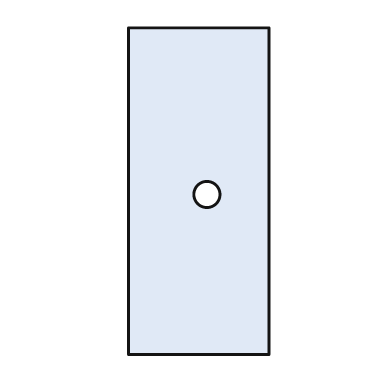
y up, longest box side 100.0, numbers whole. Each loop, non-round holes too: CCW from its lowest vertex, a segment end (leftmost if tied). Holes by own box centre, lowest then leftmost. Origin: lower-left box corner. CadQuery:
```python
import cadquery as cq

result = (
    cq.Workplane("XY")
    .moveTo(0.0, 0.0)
    .lineTo(43.0, 0.0)
    .lineTo(43.0, 100.0)
    .lineTo(0.0, 100.0)
    .close()
    .moveTo(24.0, 49.0)
    .circle(4.0)
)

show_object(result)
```